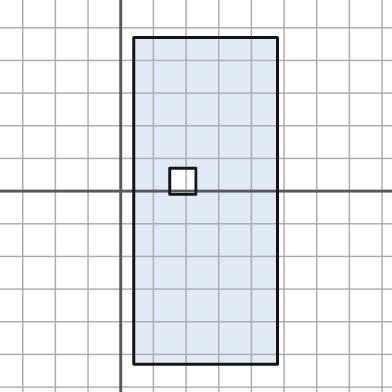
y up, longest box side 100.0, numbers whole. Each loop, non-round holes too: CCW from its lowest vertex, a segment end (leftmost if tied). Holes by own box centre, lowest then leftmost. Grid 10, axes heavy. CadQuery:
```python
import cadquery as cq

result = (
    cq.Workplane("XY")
    .moveTo(4.0, -53.0)
    .lineTo(48.0, -53.0)
    .lineTo(48.0, 47.0)
    .lineTo(4.0, 47.0)
    .close()
    .moveTo(15.0, -1.0)
    .lineTo(23.0, -1.0)
    .lineTo(23.0, 7.0)
    .lineTo(15.0, 7.0)
    .close()
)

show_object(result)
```